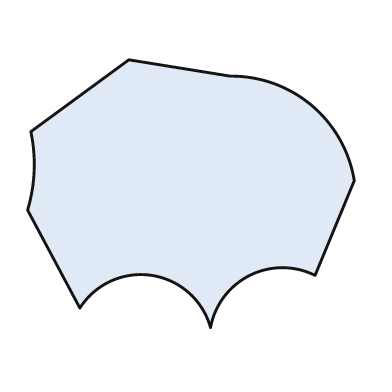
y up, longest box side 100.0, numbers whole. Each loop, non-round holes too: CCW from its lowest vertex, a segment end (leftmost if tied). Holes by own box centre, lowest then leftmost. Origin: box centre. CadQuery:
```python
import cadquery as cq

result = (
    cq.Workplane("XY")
    .moveTo(6.0, -41.0)
    .threePointArc((18.0, -25.0), (38.0, -25.0))
    .lineTo(50.0, 4.0)
    .threePointArc((37.0, 27.0), (12.0, 36.0))
    .lineTo(-19.0, 41.0)
    .lineTo(-49.0, 19.0)
    .threePointArc((-48.0, 7.0), (-50.0, -5.0))
    .lineTo(-34.0, -35.0)
    .threePointArc((-12.0, -25.0), (6.0, -41.0))
    .close()
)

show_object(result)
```